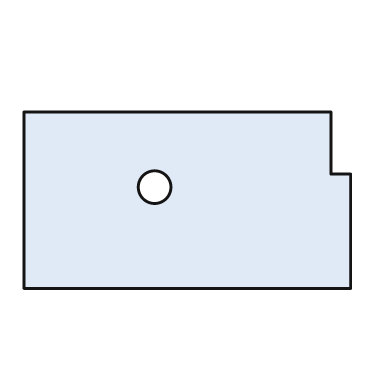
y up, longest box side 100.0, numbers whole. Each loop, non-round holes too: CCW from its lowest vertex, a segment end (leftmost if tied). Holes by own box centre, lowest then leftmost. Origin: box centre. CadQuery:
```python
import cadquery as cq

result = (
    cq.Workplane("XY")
    .moveTo(-50.0, -27.0)
    .lineTo(50.0, -27.0)
    .lineTo(50.0, 8.0)
    .lineTo(44.0, 8.0)
    .lineTo(44.0, 27.0)
    .lineTo(-50.0, 27.0)
    .close()
    .moveTo(-10.0, 4.0)
    .circle(5.0)
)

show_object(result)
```